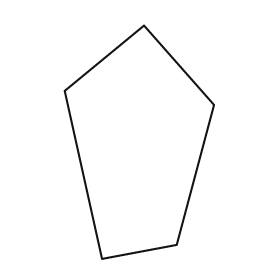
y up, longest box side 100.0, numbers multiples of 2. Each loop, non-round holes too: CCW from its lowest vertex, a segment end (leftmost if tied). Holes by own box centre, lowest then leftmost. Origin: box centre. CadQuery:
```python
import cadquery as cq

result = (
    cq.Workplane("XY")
    .moveTo(-16.0, -50.0)
    .lineTo(16.0, -44.0)
    .lineTo(32.0, 16.0)
    .lineTo(2.0, 50.0)
    .lineTo(-32.0, 22.0)
    .close()
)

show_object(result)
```